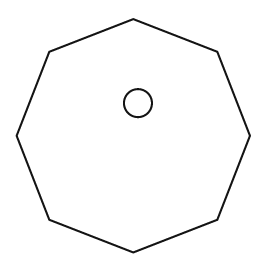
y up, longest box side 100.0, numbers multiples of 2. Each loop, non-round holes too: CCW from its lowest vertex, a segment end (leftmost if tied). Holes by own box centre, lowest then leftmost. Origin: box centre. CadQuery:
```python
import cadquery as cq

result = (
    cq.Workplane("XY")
    .moveTo(0.0, -50.0)
    .lineTo(36.0, -36.0)
    .lineTo(50.0, 0.0)
    .lineTo(36.0, 36.0)
    .lineTo(0.0, 50.0)
    .lineTo(-36.0, 36.0)
    .lineTo(-50.0, 0.0)
    .lineTo(-36.0, -36.0)
    .close()
    .moveTo(2.0, 14.0)
    .circle(6.0)
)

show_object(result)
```